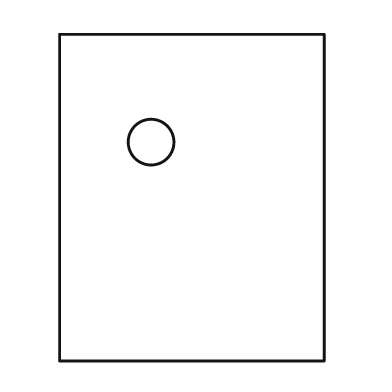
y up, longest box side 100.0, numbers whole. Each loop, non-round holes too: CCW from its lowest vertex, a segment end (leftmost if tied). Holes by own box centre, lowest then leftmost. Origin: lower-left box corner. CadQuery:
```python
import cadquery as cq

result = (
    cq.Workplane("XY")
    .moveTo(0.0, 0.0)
    .lineTo(81.0, 0.0)
    .lineTo(81.0, 100.0)
    .lineTo(0.0, 100.0)
    .close()
    .moveTo(28.0, 67.0)
    .circle(7.0)
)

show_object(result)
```